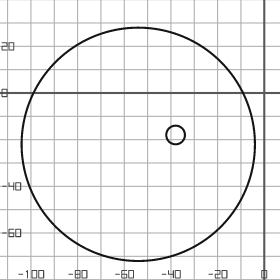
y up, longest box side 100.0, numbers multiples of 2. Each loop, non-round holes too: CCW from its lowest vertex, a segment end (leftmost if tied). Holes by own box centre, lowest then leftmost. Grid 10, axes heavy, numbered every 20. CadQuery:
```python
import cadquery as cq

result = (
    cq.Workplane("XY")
    .moveTo(-54.0, -22.0)
    .circle(50.0)
    .moveTo(-38.0, -18.0)
    .circle(4.0)
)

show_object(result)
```